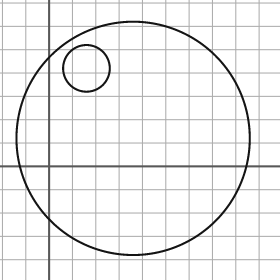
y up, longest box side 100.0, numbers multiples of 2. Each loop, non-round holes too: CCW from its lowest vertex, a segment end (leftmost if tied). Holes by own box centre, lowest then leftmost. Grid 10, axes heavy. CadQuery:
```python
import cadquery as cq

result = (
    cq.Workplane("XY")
    .moveTo(36.0, 12.0)
    .circle(50.0)
    .moveTo(16.0, 42.0)
    .circle(10.0)
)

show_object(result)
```